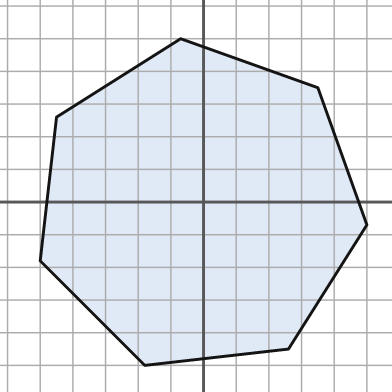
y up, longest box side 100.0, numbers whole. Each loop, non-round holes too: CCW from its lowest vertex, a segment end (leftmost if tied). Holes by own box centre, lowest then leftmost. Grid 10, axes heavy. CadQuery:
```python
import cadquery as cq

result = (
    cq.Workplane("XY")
    .moveTo(-18.0, -50.0)
    .lineTo(26.0, -45.0)
    .lineTo(50.0, -7.0)
    .lineTo(35.0, 35.0)
    .lineTo(-7.0, 50.0)
    .lineTo(-45.0, 26.0)
    .lineTo(-50.0, -18.0)
    .close()
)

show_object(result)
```